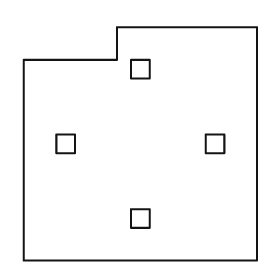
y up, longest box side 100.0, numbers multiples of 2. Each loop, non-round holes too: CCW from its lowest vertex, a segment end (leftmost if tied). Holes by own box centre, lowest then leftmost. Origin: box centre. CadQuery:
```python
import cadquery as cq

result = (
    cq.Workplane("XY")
    .moveTo(-50.0, -50.0)
    .lineTo(50.0, -50.0)
    .lineTo(50.0, 50.0)
    .lineTo(-10.0, 50.0)
    .lineTo(-10.0, 36.0)
    .lineTo(-50.0, 36.0)
    .close()
    .moveTo(-4.0, -36.0)
    .lineTo(4.0, -36.0)
    .lineTo(4.0, -28.0)
    .lineTo(-4.0, -28.0)
    .close()
    .moveTo(-36.0, -4.0)
    .lineTo(-28.0, -4.0)
    .lineTo(-28.0, 4.0)
    .lineTo(-36.0, 4.0)
    .close()
    .moveTo(28.0, -4.0)
    .lineTo(36.0, -4.0)
    .lineTo(36.0, 4.0)
    .lineTo(28.0, 4.0)
    .close()
    .moveTo(-4.0, 28.0)
    .lineTo(4.0, 28.0)
    .lineTo(4.0, 36.0)
    .lineTo(-4.0, 36.0)
    .close()
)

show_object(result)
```